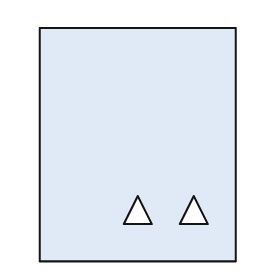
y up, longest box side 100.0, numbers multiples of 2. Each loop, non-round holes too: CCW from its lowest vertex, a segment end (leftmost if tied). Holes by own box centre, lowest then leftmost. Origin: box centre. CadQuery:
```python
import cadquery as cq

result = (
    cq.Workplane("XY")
    .moveTo(-42.0, -50.0)
    .lineTo(42.0, -50.0)
    .lineTo(42.0, 50.0)
    .lineTo(-42.0, 50.0)
    .close()
    .moveTo(-6.0, -34.0)
    .lineTo(6.0, -34.0)
    .lineTo(0.0, -22.0)
    .close()
    .moveTo(18.0, -34.0)
    .lineTo(30.0, -34.0)
    .lineTo(24.0, -22.0)
    .close()
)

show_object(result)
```